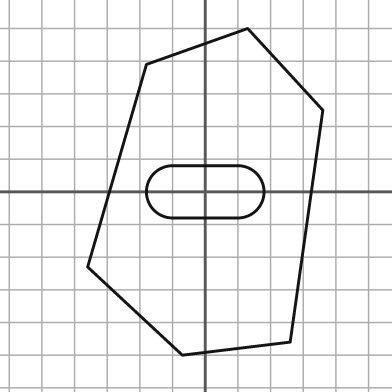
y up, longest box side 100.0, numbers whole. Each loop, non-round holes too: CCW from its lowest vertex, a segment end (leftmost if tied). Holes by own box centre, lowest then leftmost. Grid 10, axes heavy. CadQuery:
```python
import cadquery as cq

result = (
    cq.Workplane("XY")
    .moveTo(-7.0, -50.0)
    .lineTo(26.0, -46.0)
    .lineTo(36.0, 25.0)
    .lineTo(13.0, 50.0)
    .lineTo(-18.0, 39.0)
    .lineTo(-36.0, -23.0)
    .close()
    .moveTo(-10.0, -8.0)
    .lineTo(10.0, -8.0)
    .threePointArc((18.0, 0.0), (10.0, 8.0))
    .lineTo(-10.0, 8.0)
    .threePointArc((-18.0, 0.0), (-10.0, -8.0))
    .close()
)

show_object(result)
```